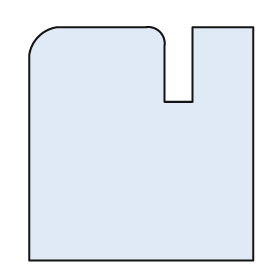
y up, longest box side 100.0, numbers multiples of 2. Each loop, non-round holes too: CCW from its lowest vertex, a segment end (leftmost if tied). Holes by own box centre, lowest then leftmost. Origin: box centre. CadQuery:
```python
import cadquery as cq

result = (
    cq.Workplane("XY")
    .moveTo(-48.0, -50.0)
    .lineTo(48.0, -50.0)
    .lineTo(48.0, 50.0)
    .lineTo(22.0, 50.0)
    .lineTo(22.0, 18.0)
    .lineTo(10.0, 18.0)
    .lineTo(10.0, 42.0)
    .threePointArc((8.0, 48.0), (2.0, 50.0))
    .lineTo(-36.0, 50.0)
    .threePointArc((-44.0, 46.0), (-48.0, 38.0))
    .close()
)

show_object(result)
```